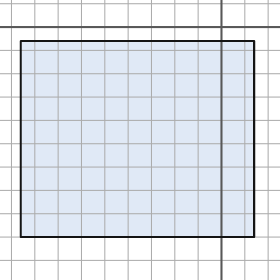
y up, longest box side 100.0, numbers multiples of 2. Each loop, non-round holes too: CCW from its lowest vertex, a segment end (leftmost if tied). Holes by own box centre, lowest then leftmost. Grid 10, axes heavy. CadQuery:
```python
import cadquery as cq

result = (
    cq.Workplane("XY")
    .moveTo(-86.0, -90.0)
    .lineTo(14.0, -90.0)
    .lineTo(14.0, -6.0)
    .lineTo(-86.0, -6.0)
    .close()
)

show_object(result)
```